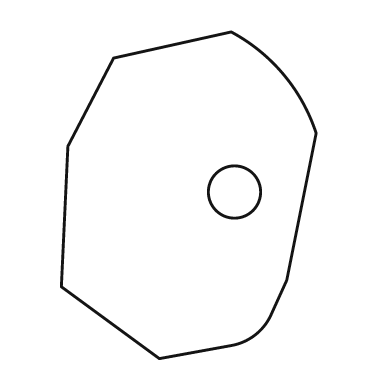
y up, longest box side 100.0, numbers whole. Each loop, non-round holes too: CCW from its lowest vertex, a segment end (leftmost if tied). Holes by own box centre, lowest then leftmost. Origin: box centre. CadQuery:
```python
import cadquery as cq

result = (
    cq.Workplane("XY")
    .moveTo(-9.0, -50.0)
    .lineTo(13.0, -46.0)
    .threePointArc((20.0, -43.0), (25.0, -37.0))
    .lineTo(30.0, -26.0)
    .lineTo(39.0, 19.0)
    .threePointArc((29.0, 37.0), (13.0, 50.0))
    .lineTo(-23.0, 42.0)
    .lineTo(-37.0, 15.0)
    .lineTo(-39.0, -28.0)
    .close()
    .moveTo(14.0, 1.0)
    .circle(8.0)
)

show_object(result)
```